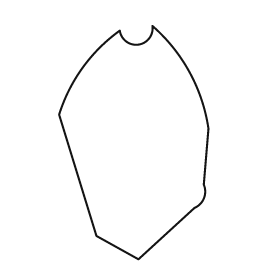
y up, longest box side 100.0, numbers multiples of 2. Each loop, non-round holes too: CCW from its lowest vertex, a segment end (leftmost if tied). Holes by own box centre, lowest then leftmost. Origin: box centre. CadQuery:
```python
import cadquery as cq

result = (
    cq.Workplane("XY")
    .moveTo(2.0, -50.0)
    .lineTo(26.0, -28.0)
    .threePointArc((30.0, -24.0), (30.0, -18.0))
    .lineTo(32.0, 6.0)
    .threePointArc((24.0, 30.0), (8.0, 50.0))
    .threePointArc((2.0, 42.0), (-6.0, 48.0))
    .threePointArc((-22.0, 32.0), (-32.0, 12.0))
    .lineTo(-16.0, -40.0)
    .close()
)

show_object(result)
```